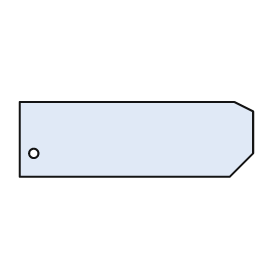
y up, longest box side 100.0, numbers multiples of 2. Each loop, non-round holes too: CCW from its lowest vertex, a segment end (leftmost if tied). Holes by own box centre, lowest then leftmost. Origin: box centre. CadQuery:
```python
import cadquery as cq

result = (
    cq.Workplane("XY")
    .moveTo(-50.0, -16.0)
    .lineTo(40.0, -16.0)
    .lineTo(50.0, -6.0)
    .lineTo(50.0, 12.0)
    .lineTo(42.0, 16.0)
    .lineTo(-50.0, 16.0)
    .close()
    .moveTo(-44.0, -6.0)
    .circle(2.0)
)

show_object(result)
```